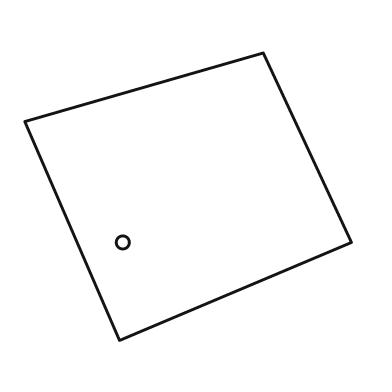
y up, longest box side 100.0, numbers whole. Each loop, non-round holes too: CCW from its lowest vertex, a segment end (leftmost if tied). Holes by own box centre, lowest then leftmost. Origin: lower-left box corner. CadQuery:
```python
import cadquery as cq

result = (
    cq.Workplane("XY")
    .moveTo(29.0, 0.0)
    .lineTo(100.0, 30.0)
    .lineTo(73.0, 88.0)
    .lineTo(0.0, 67.0)
    .close()
    .moveTo(30.0, 30.0)
    .circle(2.0)
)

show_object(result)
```